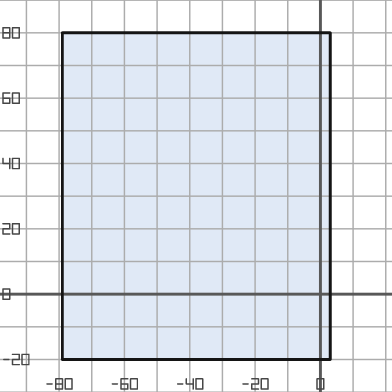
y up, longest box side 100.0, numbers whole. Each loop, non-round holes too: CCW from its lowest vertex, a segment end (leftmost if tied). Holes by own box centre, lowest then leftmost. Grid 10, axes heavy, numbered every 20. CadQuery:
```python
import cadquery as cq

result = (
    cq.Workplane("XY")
    .moveTo(-79.0, -20.0)
    .lineTo(3.0, -20.0)
    .lineTo(3.0, 80.0)
    .lineTo(-79.0, 80.0)
    .close()
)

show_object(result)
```